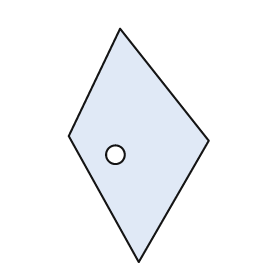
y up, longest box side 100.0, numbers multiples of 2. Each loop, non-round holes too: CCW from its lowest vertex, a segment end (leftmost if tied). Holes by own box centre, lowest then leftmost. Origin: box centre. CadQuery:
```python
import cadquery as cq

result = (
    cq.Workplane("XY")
    .moveTo(0.0, -50.0)
    .lineTo(30.0, 2.0)
    .lineTo(-8.0, 50.0)
    .lineTo(-30.0, 4.0)
    .close()
    .moveTo(-10.0, -4.0)
    .circle(4.0)
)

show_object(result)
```